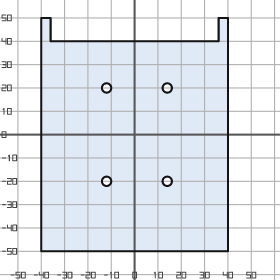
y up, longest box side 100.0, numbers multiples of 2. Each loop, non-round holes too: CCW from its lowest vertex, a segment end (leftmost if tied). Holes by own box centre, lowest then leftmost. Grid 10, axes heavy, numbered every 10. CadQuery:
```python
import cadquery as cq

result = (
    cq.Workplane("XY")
    .moveTo(-40.0, -50.0)
    .lineTo(40.0, -50.0)
    .lineTo(40.0, 50.0)
    .lineTo(36.0, 50.0)
    .lineTo(36.0, 40.0)
    .lineTo(-36.0, 40.0)
    .lineTo(-36.0, 50.0)
    .lineTo(-40.0, 50.0)
    .close()
    .moveTo(-12.0, -20.0)
    .circle(2.0)
    .moveTo(14.0, -20.0)
    .circle(2.0)
    .moveTo(-12.0, 20.0)
    .circle(2.0)
    .moveTo(14.0, 20.0)
    .circle(2.0)
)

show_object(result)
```